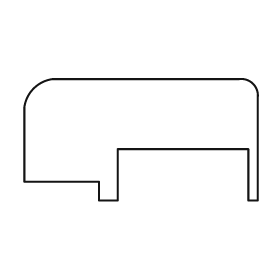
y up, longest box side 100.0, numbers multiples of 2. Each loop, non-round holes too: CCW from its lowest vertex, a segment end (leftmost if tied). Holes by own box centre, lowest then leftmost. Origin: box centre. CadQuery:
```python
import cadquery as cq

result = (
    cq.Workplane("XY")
    .moveTo(-18.0, -26.0)
    .lineTo(-10.0, -26.0)
    .lineTo(-10.0, -4.0)
    .lineTo(46.0, -4.0)
    .lineTo(46.0, -26.0)
    .lineTo(50.0, -26.0)
    .lineTo(50.0, 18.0)
    .threePointArc((48.0, 24.0), (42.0, 26.0))
    .lineTo(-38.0, 26.0)
    .threePointArc((-46.0, 22.0), (-50.0, 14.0))
    .lineTo(-50.0, -18.0)
    .lineTo(-18.0, -18.0)
    .close()
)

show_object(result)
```